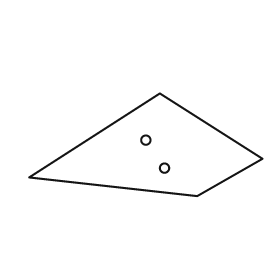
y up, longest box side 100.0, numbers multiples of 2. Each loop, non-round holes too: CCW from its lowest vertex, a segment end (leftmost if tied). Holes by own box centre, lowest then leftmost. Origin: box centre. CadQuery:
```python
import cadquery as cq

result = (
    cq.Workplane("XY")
    .moveTo(22.0, -22.0)
    .lineTo(50.0, -6.0)
    .lineTo(6.0, 22.0)
    .lineTo(-50.0, -14.0)
    .close()
    .moveTo(8.0, -10.0)
    .circle(2.0)
    .moveTo(0.0, 2.0)
    .circle(2.0)
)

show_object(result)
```